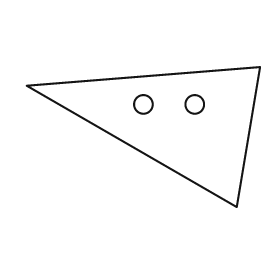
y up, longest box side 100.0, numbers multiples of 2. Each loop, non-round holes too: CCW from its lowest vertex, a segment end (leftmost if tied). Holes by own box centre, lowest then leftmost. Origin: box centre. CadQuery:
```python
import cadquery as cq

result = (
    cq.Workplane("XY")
    .moveTo(40.0, -30.0)
    .lineTo(50.0, 30.0)
    .lineTo(-50.0, 22.0)
    .close()
    .moveTo(0.0, 14.0)
    .circle(4.0)
    .moveTo(22.0, 14.0)
    .circle(4.0)
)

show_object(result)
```